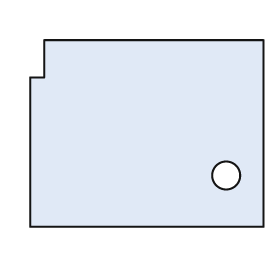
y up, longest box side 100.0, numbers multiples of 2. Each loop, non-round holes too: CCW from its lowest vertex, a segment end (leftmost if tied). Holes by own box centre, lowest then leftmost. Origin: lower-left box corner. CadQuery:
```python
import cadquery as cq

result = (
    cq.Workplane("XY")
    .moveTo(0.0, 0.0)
    .lineTo(100.0, 0.0)
    .lineTo(100.0, 80.0)
    .lineTo(6.0, 80.0)
    .lineTo(6.0, 64.0)
    .lineTo(0.0, 64.0)
    .close()
    .moveTo(84.0, 22.0)
    .circle(6.0)
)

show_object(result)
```